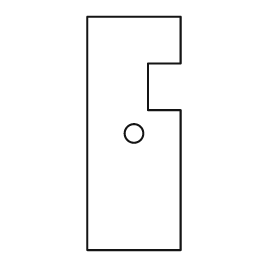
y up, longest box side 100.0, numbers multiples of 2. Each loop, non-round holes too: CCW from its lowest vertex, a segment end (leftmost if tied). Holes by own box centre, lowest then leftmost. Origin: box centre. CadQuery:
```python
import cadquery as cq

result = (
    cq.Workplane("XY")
    .moveTo(-20.0, -50.0)
    .lineTo(20.0, -50.0)
    .lineTo(20.0, 10.0)
    .lineTo(6.0, 10.0)
    .lineTo(6.0, 30.0)
    .lineTo(20.0, 30.0)
    .lineTo(20.0, 50.0)
    .lineTo(-20.0, 50.0)
    .close()
    .moveTo(0.0, 0.0)
    .circle(4.0)
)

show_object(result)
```